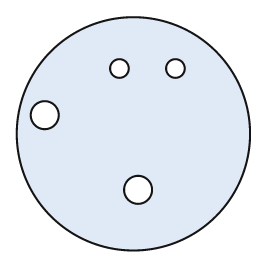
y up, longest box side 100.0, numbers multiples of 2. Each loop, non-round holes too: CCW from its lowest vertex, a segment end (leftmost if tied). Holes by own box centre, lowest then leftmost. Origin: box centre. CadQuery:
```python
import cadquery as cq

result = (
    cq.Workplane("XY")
    .moveTo(0.0, 0.0)
    .circle(50.0)
    .moveTo(2.0, -24.0)
    .circle(6.0)
    .moveTo(-38.0, 8.0)
    .circle(6.0)
    .moveTo(-6.0, 28.0)
    .circle(4.0)
    .moveTo(18.0, 28.0)
    .circle(4.0)
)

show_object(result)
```